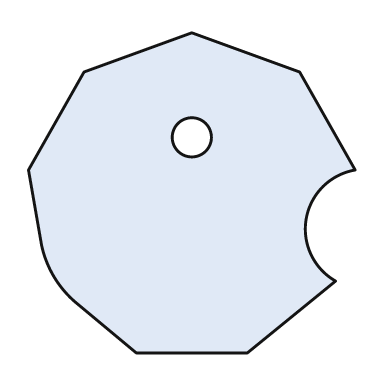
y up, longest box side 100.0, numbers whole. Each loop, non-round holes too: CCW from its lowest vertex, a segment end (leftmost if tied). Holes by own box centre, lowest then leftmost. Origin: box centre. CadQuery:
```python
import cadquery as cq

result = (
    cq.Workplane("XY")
    .moveTo(-17.0, -49.0)
    .lineTo(17.0, -49.0)
    .lineTo(44.0, -27.0)
    .threePointArc((35.0, -8.0), (50.0, 7.0))
    .lineTo(33.0, 37.0)
    .lineTo(0.0, 49.0)
    .lineTo(-33.0, 37.0)
    .lineTo(-50.0, 7.0)
    .lineTo(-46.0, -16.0)
    .threePointArc((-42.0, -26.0), (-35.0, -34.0))
    .close()
    .moveTo(0.0, 17.0)
    .circle(6.0)
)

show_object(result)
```